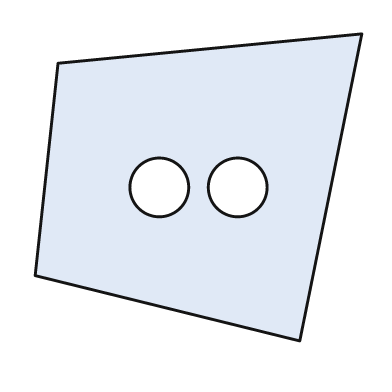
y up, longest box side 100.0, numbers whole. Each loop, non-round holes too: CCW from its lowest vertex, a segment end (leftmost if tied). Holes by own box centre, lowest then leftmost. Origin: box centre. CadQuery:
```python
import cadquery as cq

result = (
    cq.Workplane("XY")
    .moveTo(31.0, -47.0)
    .lineTo(50.0, 47.0)
    .lineTo(-43.0, 38.0)
    .lineTo(-50.0, -27.0)
    .close()
    .moveTo(-12.0, 0.0)
    .circle(9.0)
    .moveTo(12.0, 0.0)
    .circle(9.0)
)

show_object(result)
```